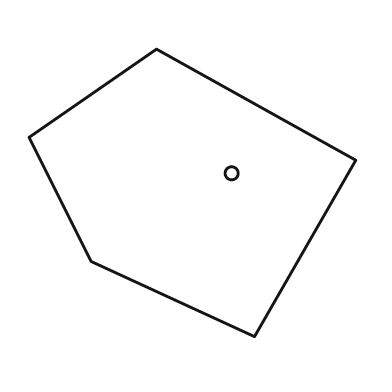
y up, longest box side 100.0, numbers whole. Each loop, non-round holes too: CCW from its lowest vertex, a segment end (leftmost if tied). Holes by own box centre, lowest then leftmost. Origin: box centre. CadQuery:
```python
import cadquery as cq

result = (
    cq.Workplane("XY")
    .moveTo(19.0, -44.0)
    .lineTo(50.0, 10.0)
    .lineTo(-11.0, 44.0)
    .lineTo(-50.0, 17.0)
    .lineTo(-31.0, -21.0)
    .close()
    .moveTo(12.0, 6.0)
    .circle(2.0)
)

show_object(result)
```